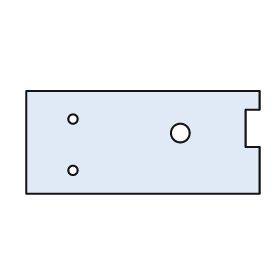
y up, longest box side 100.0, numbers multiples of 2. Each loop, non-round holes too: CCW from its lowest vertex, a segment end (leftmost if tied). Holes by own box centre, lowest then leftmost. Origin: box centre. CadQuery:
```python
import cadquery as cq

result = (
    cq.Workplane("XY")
    .moveTo(-50.0, -22.0)
    .lineTo(50.0, -22.0)
    .lineTo(50.0, -2.0)
    .lineTo(44.0, -2.0)
    .lineTo(44.0, 14.0)
    .lineTo(50.0, 14.0)
    .lineTo(50.0, 22.0)
    .lineTo(-50.0, 22.0)
    .close()
    .moveTo(-30.0, -12.0)
    .circle(2.0)
    .moveTo(16.0, 4.0)
    .circle(4.0)
    .moveTo(-30.0, 10.0)
    .circle(2.0)
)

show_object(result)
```